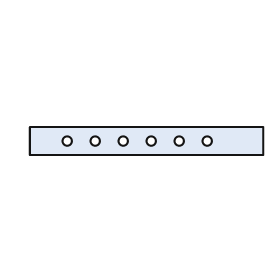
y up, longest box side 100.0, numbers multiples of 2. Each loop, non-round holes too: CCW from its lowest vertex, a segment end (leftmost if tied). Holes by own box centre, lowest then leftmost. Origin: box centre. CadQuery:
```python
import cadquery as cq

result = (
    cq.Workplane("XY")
    .moveTo(-50.0, -6.0)
    .lineTo(50.0, -6.0)
    .lineTo(50.0, 6.0)
    .lineTo(-50.0, 6.0)
    .close()
    .moveTo(-34.0, 0.0)
    .circle(2.0)
    .moveTo(-22.0, 0.0)
    .circle(2.0)
    .moveTo(-10.0, 0.0)
    .circle(2.0)
    .moveTo(2.0, 0.0)
    .circle(2.0)
    .moveTo(14.0, 0.0)
    .circle(2.0)
    .moveTo(26.0, 0.0)
    .circle(2.0)
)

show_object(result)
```